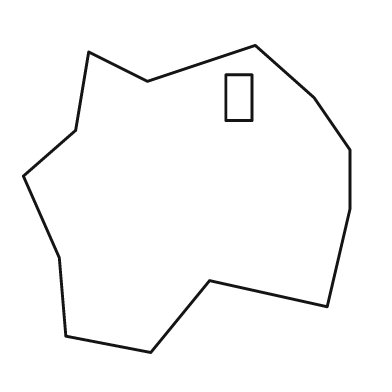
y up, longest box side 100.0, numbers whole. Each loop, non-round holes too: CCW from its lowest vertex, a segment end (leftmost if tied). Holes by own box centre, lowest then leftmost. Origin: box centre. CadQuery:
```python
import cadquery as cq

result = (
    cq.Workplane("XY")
    .moveTo(-11.0, -47.0)
    .lineTo(7.0, -25.0)
    .lineTo(43.0, -33.0)
    .lineTo(50.0, -3.0)
    .lineTo(50.0, 15.0)
    .lineTo(39.0, 31.0)
    .lineTo(21.0, 47.0)
    .lineTo(-12.0, 36.0)
    .lineTo(-30.0, 45.0)
    .lineTo(-34.0, 21.0)
    .lineTo(-50.0, 7.0)
    .lineTo(-39.0, -18.0)
    .lineTo(-37.0, -42.0)
    .close()
    .moveTo(12.0, 24.0)
    .lineTo(20.0, 24.0)
    .lineTo(20.0, 38.0)
    .lineTo(12.0, 38.0)
    .close()
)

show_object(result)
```